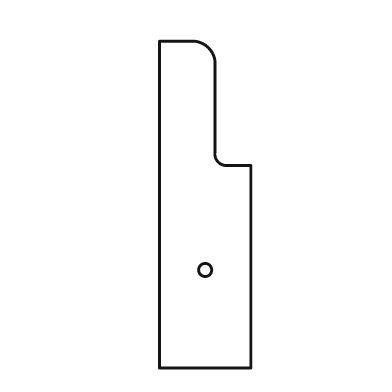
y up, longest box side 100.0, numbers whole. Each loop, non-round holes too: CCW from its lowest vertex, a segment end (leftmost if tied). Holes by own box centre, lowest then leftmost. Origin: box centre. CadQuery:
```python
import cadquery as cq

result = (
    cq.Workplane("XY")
    .moveTo(-14.0, -50.0)
    .lineTo(14.0, -50.0)
    .lineTo(14.0, 12.0)
    .lineTo(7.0, 12.0)
    .threePointArc((4.0, 13.0), (3.0, 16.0))
    .lineTo(3.0, 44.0)
    .threePointArc((1.0, 48.0), (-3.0, 50.0))
    .lineTo(-14.0, 50.0)
    .close()
    .moveTo(0.0, -20.0)
    .circle(2.0)
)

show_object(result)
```